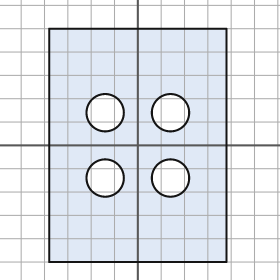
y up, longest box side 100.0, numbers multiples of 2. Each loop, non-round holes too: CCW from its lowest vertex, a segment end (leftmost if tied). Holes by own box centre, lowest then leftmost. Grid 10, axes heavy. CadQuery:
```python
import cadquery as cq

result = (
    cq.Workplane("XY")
    .moveTo(-38.0, -50.0)
    .lineTo(38.0, -50.0)
    .lineTo(38.0, 50.0)
    .lineTo(-38.0, 50.0)
    .close()
    .moveTo(-14.0, -14.0)
    .circle(8.0)
    .moveTo(14.0, -14.0)
    .circle(8.0)
    .moveTo(-14.0, 14.0)
    .circle(8.0)
    .moveTo(14.0, 14.0)
    .circle(8.0)
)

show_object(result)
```